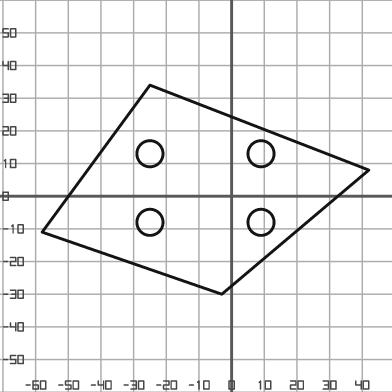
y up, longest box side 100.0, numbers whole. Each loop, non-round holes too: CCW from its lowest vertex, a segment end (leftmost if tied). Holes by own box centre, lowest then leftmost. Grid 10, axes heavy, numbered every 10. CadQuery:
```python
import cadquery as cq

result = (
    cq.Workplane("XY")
    .moveTo(-3.0, -30.0)
    .lineTo(42.0, 8.0)
    .lineTo(-25.0, 34.0)
    .lineTo(-58.0, -11.0)
    .close()
    .moveTo(-25.0, -8.0)
    .circle(4.0)
    .moveTo(9.0, -8.0)
    .circle(4.0)
    .moveTo(-25.0, 13.0)
    .circle(4.0)
    .moveTo(9.0, 13.0)
    .circle(4.0)
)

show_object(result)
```